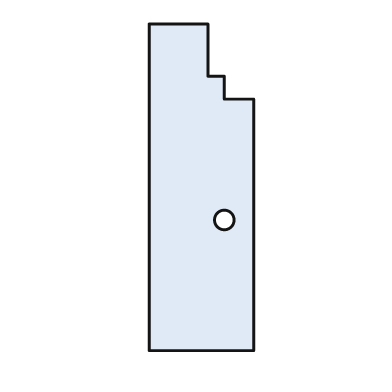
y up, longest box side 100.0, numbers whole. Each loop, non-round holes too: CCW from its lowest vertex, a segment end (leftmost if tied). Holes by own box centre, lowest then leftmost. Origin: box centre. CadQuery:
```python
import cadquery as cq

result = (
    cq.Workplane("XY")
    .moveTo(-16.0, -50.0)
    .lineTo(16.0, -50.0)
    .lineTo(16.0, 27.0)
    .lineTo(7.0, 27.0)
    .lineTo(7.0, 34.0)
    .lineTo(2.0, 34.0)
    .lineTo(2.0, 50.0)
    .lineTo(-16.0, 50.0)
    .close()
    .moveTo(7.0, -10.0)
    .circle(3.0)
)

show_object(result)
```